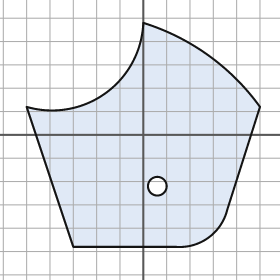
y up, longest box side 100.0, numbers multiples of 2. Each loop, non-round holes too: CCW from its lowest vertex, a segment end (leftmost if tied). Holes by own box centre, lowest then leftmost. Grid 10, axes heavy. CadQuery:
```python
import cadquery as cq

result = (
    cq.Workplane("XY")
    .moveTo(-30.0, -48.0)
    .lineTo(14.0, -48.0)
    .threePointArc((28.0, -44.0), (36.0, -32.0))
    .lineTo(50.0, 12.0)
    .threePointArc((28.0, 34.0), (0.0, 48.0))
    .threePointArc((-16.0, 18.0), (-50.0, 12.0))
    .close()
    .moveTo(6.0, -22.0)
    .circle(4.0)
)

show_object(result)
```